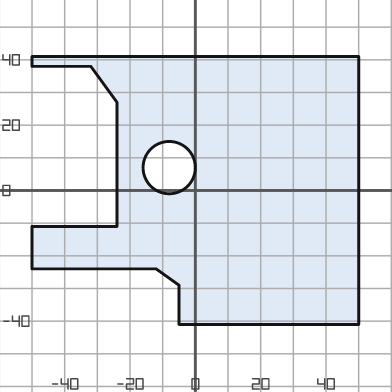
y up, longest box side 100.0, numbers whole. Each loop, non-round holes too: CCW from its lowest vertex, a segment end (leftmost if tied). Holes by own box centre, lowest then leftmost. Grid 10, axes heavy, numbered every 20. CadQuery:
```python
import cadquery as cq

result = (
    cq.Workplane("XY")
    .moveTo(-5.0, -41.0)
    .lineTo(50.0, -41.0)
    .lineTo(50.0, 41.0)
    .lineTo(-50.0, 41.0)
    .lineTo(-50.0, 38.0)
    .lineTo(-32.0, 38.0)
    .lineTo(-24.0, 27.0)
    .lineTo(-24.0, -11.0)
    .lineTo(-50.0, -11.0)
    .lineTo(-50.0, -24.0)
    .lineTo(-12.0, -24.0)
    .lineTo(-5.0, -29.0)
    .close()
    .moveTo(-8.0, 7.0)
    .circle(8.0)
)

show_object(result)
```